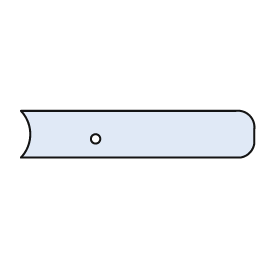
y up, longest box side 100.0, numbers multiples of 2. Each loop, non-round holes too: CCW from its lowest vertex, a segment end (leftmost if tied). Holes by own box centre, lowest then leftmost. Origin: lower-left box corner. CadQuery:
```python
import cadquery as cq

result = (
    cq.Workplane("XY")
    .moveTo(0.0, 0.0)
    .lineTo(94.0, 0.0)
    .threePointArc((98.0, 2.0), (100.0, 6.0))
    .lineTo(100.0, 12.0)
    .threePointArc((98.0, 18.0), (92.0, 20.0))
    .lineTo(0.0, 20.0)
    .threePointArc((4.0, 10.0), (0.0, 0.0))
    .close()
    .moveTo(32.0, 8.0)
    .circle(2.0)
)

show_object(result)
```